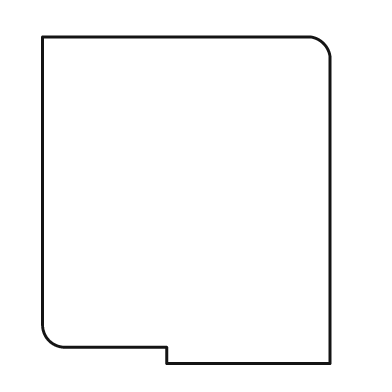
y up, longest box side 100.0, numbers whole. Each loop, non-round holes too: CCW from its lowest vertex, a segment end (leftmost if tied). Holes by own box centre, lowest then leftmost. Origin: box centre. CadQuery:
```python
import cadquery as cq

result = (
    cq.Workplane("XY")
    .moveTo(-6.0, -50.0)
    .lineTo(44.0, -50.0)
    .lineTo(44.0, 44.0)
    .threePointArc((42.0, 48.0), (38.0, 50.0))
    .lineTo(-44.0, 50.0)
    .lineTo(-44.0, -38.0)
    .threePointArc((-42.0, -43.0), (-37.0, -45.0))
    .lineTo(-6.0, -45.0)
    .close()
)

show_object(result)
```